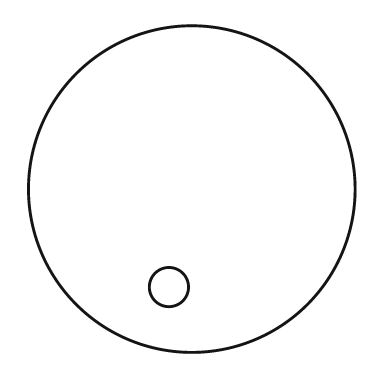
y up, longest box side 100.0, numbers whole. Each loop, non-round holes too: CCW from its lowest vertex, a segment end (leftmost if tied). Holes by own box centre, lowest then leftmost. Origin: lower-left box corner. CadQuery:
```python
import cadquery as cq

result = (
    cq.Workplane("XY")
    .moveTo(50.0, 50.0)
    .circle(50.0)
    .moveTo(43.0, 20.0)
    .circle(6.0)
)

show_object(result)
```